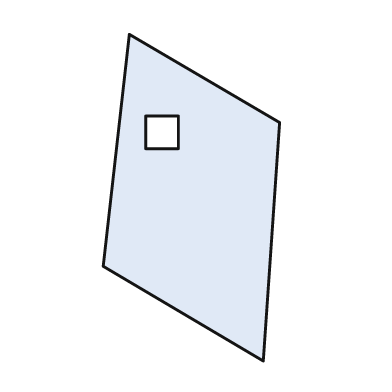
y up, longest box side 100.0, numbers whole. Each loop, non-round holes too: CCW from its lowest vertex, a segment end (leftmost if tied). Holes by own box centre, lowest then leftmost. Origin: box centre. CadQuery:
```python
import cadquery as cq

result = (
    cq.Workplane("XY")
    .moveTo(22.0, -50.0)
    .lineTo(27.0, 23.0)
    .lineTo(-19.0, 50.0)
    .lineTo(-27.0, -21.0)
    .close()
    .moveTo(-14.0, 15.0)
    .lineTo(-4.0, 15.0)
    .lineTo(-4.0, 25.0)
    .lineTo(-14.0, 25.0)
    .close()
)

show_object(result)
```